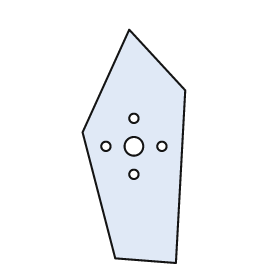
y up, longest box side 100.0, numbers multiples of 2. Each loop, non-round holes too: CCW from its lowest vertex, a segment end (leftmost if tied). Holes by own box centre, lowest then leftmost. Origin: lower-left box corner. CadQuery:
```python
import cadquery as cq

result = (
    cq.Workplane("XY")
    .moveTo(40.0, 0.0)
    .lineTo(44.0, 74.0)
    .lineTo(20.0, 100.0)
    .lineTo(0.0, 56.0)
    .lineTo(14.0, 2.0)
    .close()
    .moveTo(22.0, 38.0)
    .circle(2.0)
    .moveTo(10.0, 50.0)
    .circle(2.0)
    .moveTo(22.0, 50.0)
    .circle(4.0)
    .moveTo(34.0, 50.0)
    .circle(2.0)
    .moveTo(22.0, 62.0)
    .circle(2.0)
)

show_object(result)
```